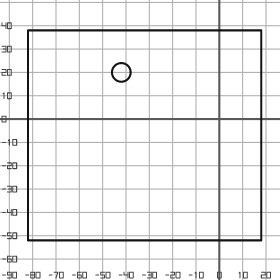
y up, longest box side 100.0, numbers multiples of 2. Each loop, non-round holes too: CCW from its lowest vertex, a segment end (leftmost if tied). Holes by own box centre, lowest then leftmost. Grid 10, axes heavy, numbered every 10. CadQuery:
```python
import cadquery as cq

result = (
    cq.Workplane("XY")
    .moveTo(-82.0, -52.0)
    .lineTo(18.0, -52.0)
    .lineTo(18.0, 38.0)
    .lineTo(-82.0, 38.0)
    .close()
    .moveTo(-42.0, 20.0)
    .circle(4.0)
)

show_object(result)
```